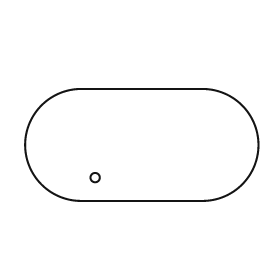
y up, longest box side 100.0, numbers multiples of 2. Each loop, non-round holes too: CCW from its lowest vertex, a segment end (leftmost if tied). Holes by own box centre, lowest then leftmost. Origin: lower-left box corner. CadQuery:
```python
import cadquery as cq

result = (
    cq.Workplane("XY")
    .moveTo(24.0, 0.0)
    .lineTo(76.0, 0.0)
    .threePointArc((100.0, 24.0), (76.0, 48.0))
    .lineTo(24.0, 48.0)
    .threePointArc((0.0, 24.0), (24.0, 0.0))
    .close()
    .moveTo(30.0, 10.0)
    .circle(2.0)
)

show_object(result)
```